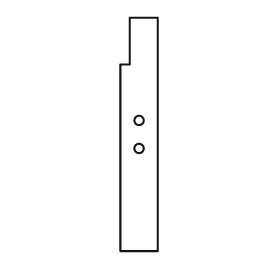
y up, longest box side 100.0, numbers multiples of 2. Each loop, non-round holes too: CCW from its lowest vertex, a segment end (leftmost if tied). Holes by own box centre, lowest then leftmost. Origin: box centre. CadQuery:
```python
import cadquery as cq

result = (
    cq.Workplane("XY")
    .moveTo(-8.0, -50.0)
    .lineTo(8.0, -50.0)
    .lineTo(8.0, 50.0)
    .lineTo(-4.0, 50.0)
    .lineTo(-4.0, 30.0)
    .lineTo(-8.0, 30.0)
    .close()
    .moveTo(0.0, -6.0)
    .circle(2.0)
    .moveTo(0.0, 6.0)
    .circle(2.0)
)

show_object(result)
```